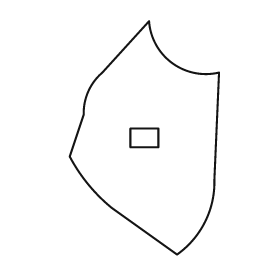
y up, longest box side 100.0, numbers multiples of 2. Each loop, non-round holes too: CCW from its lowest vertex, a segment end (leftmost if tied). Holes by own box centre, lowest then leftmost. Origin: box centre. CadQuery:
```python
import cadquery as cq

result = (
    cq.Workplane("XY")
    .moveTo(14.0, -50.0)
    .threePointArc((26.0, -36.0), (30.0, -18.0))
    .lineTo(32.0, 28.0)
    .threePointArc((12.0, 32.0), (2.0, 50.0))
    .lineTo(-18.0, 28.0)
    .threePointArc((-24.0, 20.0), (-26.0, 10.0))
    .lineTo(-32.0, -8.0)
    .threePointArc((-24.0, -20.0), (-14.0, -30.0))
    .close()
    .moveTo(-6.0, -4.0)
    .lineTo(6.0, -4.0)
    .lineTo(6.0, 4.0)
    .lineTo(-6.0, 4.0)
    .close()
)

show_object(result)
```